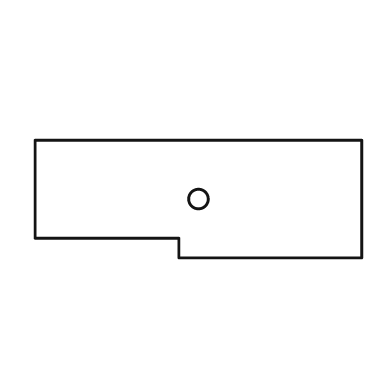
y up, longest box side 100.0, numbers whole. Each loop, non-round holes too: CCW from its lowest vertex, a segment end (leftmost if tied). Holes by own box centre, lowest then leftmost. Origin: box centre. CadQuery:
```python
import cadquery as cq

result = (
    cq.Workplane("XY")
    .moveTo(-6.0, -18.0)
    .lineTo(50.0, -18.0)
    .lineTo(50.0, 18.0)
    .lineTo(-50.0, 18.0)
    .lineTo(-50.0, -12.0)
    .lineTo(-6.0, -12.0)
    .close()
    .moveTo(0.0, 0.0)
    .circle(3.0)
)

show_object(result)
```